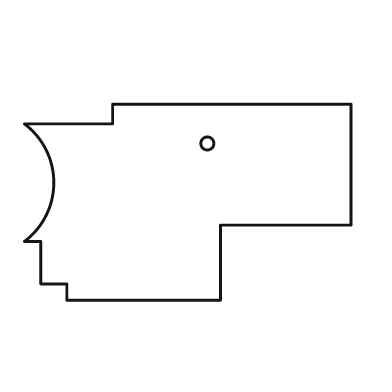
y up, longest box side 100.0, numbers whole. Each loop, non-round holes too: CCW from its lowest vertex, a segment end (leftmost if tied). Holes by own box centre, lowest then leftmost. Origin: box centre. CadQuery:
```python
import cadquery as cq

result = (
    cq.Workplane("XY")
    .moveTo(-37.0, -30.0)
    .lineTo(10.0, -30.0)
    .lineTo(10.0, -7.0)
    .lineTo(50.0, -7.0)
    .lineTo(50.0, 30.0)
    .lineTo(-23.0, 30.0)
    .lineTo(-23.0, 24.0)
    .lineTo(-50.0, 24.0)
    .threePointArc((-41.0, 6.0), (-50.0, -12.0))
    .lineTo(-45.0, -12.0)
    .lineTo(-45.0, -25.0)
    .lineTo(-37.0, -25.0)
    .close()
    .moveTo(6.0, 18.0)
    .circle(2.0)
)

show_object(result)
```